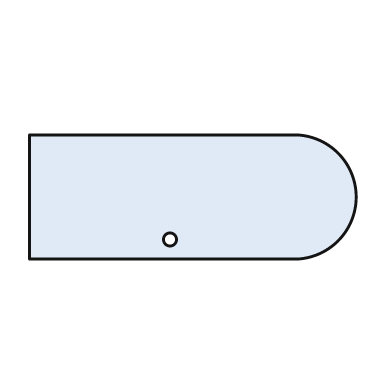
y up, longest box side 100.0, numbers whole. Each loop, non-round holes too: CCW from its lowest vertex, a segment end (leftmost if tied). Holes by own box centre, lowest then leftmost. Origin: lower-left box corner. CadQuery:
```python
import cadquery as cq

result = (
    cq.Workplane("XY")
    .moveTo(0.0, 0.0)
    .lineTo(82.0, 0.0)
    .threePointArc((100.0, 19.0), (82.0, 38.0))
    .lineTo(0.0, 38.0)
    .close()
    .moveTo(43.0, 6.0)
    .circle(2.0)
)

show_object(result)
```